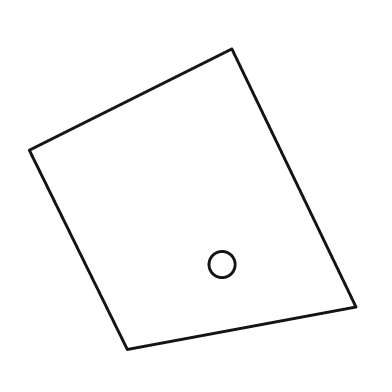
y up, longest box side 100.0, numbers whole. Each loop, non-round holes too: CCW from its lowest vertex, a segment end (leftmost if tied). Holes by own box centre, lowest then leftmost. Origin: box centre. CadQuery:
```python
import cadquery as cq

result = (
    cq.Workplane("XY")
    .moveTo(-20.0, -46.0)
    .lineTo(50.0, -33.0)
    .lineTo(12.0, 46.0)
    .lineTo(-50.0, 15.0)
    .close()
    .moveTo(9.0, -20.0)
    .circle(4.0)
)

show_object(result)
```